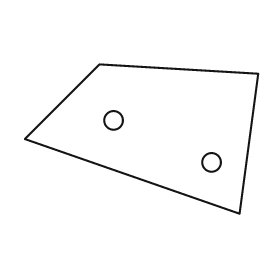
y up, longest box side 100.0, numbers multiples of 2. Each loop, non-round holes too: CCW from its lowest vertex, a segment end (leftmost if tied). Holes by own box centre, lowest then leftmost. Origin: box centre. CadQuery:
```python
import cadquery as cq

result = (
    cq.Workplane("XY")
    .moveTo(42.0, -32.0)
    .lineTo(50.0, 28.0)
    .lineTo(-18.0, 32.0)
    .lineTo(-50.0, 0.0)
    .close()
    .moveTo(30.0, -10.0)
    .circle(4.0)
    .moveTo(-12.0, 8.0)
    .circle(4.0)
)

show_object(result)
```